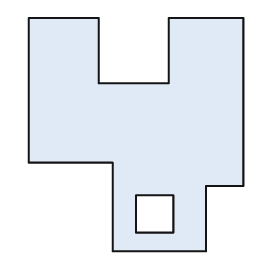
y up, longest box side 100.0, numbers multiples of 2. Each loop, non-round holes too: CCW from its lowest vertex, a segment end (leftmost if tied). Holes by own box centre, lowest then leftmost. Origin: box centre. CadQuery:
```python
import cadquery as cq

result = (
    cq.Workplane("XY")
    .moveTo(-10.0, -50.0)
    .lineTo(30.0, -50.0)
    .lineTo(30.0, -22.0)
    .lineTo(46.0, -22.0)
    .lineTo(46.0, 50.0)
    .lineTo(14.0, 50.0)
    .lineTo(14.0, 22.0)
    .lineTo(-16.0, 22.0)
    .lineTo(-16.0, 50.0)
    .lineTo(-46.0, 50.0)
    .lineTo(-46.0, -12.0)
    .lineTo(-10.0, -12.0)
    .close()
    .moveTo(0.0, -42.0)
    .lineTo(16.0, -42.0)
    .lineTo(16.0, -26.0)
    .lineTo(0.0, -26.0)
    .close()
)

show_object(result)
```